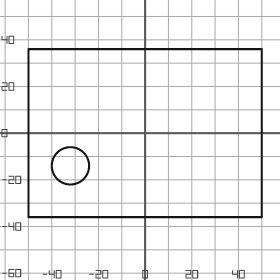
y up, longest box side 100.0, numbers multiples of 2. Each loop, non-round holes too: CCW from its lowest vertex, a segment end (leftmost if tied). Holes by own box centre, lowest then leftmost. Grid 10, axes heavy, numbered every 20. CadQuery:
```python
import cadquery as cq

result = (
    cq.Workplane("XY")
    .moveTo(-50.0, -36.0)
    .lineTo(50.0, -36.0)
    .lineTo(50.0, 36.0)
    .lineTo(-50.0, 36.0)
    .close()
    .moveTo(-32.0, -14.0)
    .circle(8.0)
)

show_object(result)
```